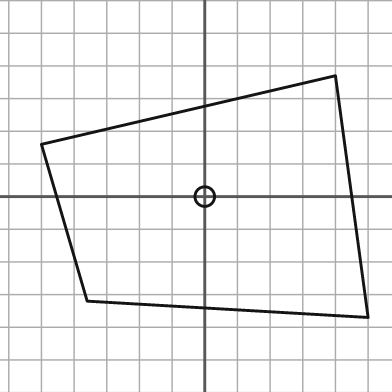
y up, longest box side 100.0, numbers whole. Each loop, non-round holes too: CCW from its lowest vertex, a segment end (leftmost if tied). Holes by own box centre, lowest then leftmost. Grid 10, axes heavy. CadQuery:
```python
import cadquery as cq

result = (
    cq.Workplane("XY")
    .moveTo(50.0, -37.0)
    .lineTo(40.0, 37.0)
    .lineTo(-50.0, 16.0)
    .lineTo(-36.0, -32.0)
    .close()
    .moveTo(0.0, 0.0)
    .circle(3.0)
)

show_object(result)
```